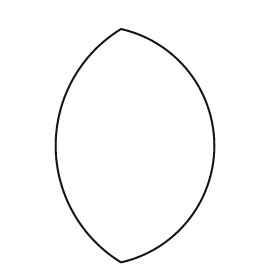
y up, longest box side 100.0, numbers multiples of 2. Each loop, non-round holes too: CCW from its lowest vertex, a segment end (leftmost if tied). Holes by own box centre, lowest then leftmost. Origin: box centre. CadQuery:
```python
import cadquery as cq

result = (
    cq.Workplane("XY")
    .moveTo(-6.0, -50.0)
    .threePointArc((34.0, 0.0), (-6.0, 50.0))
    .threePointArc((-34.0, 0.0), (-6.0, -50.0))
    .close()
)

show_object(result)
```